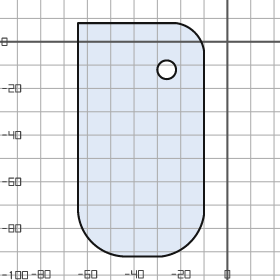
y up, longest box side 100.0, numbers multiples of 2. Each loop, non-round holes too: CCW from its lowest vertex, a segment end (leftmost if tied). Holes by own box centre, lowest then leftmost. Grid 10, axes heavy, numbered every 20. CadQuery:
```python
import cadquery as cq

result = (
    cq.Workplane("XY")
    .moveTo(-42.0, -92.0)
    .lineTo(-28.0, -92.0)
    .threePointArc((-16.0, -86.0), (-10.0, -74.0))
    .lineTo(-10.0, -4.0)
    .threePointArc((-14.0, 4.0), (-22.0, 8.0))
    .lineTo(-64.0, 8.0)
    .lineTo(-64.0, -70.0)
    .threePointArc((-58.0, -86.0), (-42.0, -92.0))
    .close()
    .moveTo(-26.0, -12.0)
    .circle(4.0)
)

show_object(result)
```